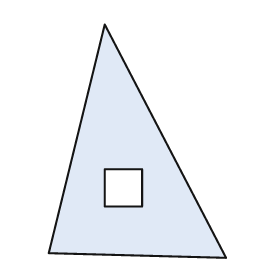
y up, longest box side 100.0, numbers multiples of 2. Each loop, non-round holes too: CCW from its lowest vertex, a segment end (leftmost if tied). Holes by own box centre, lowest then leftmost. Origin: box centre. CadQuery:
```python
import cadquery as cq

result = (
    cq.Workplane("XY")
    .moveTo(38.0, -50.0)
    .lineTo(-14.0, 50.0)
    .lineTo(-38.0, -48.0)
    .close()
    .moveTo(-14.0, -28.0)
    .lineTo(2.0, -28.0)
    .lineTo(2.0, -12.0)
    .lineTo(-14.0, -12.0)
    .close()
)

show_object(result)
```